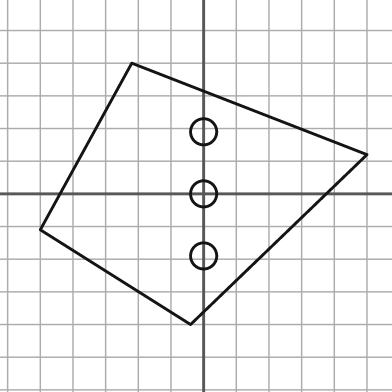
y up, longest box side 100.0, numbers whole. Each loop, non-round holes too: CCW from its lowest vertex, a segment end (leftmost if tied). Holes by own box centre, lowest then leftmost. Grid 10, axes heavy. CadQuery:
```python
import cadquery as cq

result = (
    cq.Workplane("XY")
    .moveTo(-4.0, -40.0)
    .lineTo(50.0, 12.0)
    .lineTo(-22.0, 40.0)
    .lineTo(-50.0, -11.0)
    .close()
    .moveTo(0.0, -19.0)
    .circle(4.0)
    .moveTo(0.0, 0.0)
    .circle(4.0)
    .moveTo(0.0, 19.0)
    .circle(4.0)
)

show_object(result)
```